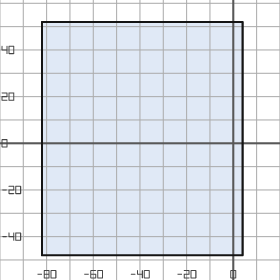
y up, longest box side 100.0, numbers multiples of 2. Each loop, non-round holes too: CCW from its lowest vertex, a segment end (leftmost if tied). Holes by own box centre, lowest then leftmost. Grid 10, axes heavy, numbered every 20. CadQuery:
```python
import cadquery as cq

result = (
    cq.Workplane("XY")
    .moveTo(-82.0, -48.0)
    .lineTo(4.0, -48.0)
    .lineTo(4.0, 52.0)
    .lineTo(-82.0, 52.0)
    .close()
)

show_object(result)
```